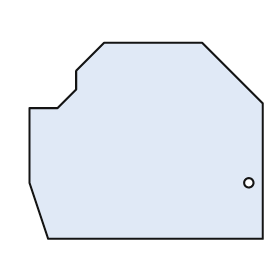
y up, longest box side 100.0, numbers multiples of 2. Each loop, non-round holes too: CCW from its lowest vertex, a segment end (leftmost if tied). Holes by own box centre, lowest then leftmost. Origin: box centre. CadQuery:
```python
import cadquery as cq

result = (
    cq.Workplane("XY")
    .moveTo(-42.0, -42.0)
    .lineTo(50.0, -42.0)
    .lineTo(50.0, 16.0)
    .lineTo(24.0, 42.0)
    .lineTo(-18.0, 42.0)
    .lineTo(-30.0, 30.0)
    .lineTo(-30.0, 22.0)
    .lineTo(-38.0, 14.0)
    .lineTo(-50.0, 14.0)
    .lineTo(-50.0, -18.0)
    .close()
    .moveTo(44.0, -18.0)
    .circle(2.0)
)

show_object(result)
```